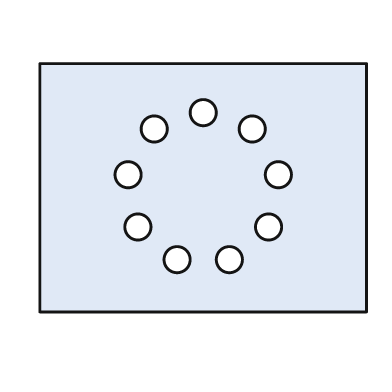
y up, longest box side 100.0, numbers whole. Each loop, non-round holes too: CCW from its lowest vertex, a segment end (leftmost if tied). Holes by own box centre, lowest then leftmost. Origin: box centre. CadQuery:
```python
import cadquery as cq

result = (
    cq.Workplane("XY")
    .moveTo(-50.0, -38.0)
    .lineTo(50.0, -38.0)
    .lineTo(50.0, 38.0)
    .lineTo(-50.0, 38.0)
    .close()
    .moveTo(-8.0, -22.0)
    .circle(4.0)
    .moveTo(8.0, -22.0)
    .circle(4.0)
    .moveTo(-20.0, -12.0)
    .circle(4.0)
    .moveTo(20.0, -12.0)
    .circle(4.0)
    .moveTo(-23.0, 4.0)
    .circle(4.0)
    .moveTo(23.0, 4.0)
    .circle(4.0)
    .moveTo(-15.0, 18.0)
    .circle(4.0)
    .moveTo(15.0, 18.0)
    .circle(4.0)
    .moveTo(0.0, 23.0)
    .circle(4.0)
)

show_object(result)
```